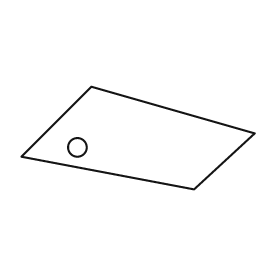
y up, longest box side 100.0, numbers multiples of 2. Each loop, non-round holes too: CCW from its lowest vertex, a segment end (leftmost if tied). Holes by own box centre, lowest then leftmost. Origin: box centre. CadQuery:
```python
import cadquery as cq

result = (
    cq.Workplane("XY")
    .moveTo(24.0, -22.0)
    .lineTo(50.0, 2.0)
    .lineTo(-20.0, 22.0)
    .lineTo(-50.0, -8.0)
    .close()
    .moveTo(-26.0, -4.0)
    .circle(4.0)
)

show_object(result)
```